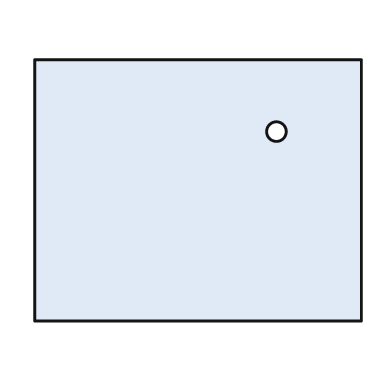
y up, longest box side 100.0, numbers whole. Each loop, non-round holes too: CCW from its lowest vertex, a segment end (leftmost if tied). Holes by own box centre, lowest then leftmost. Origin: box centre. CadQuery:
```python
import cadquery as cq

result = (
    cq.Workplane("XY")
    .moveTo(-50.0, -40.0)
    .lineTo(50.0, -40.0)
    .lineTo(50.0, 40.0)
    .lineTo(-50.0, 40.0)
    .close()
    .moveTo(24.0, 18.0)
    .circle(3.0)
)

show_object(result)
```